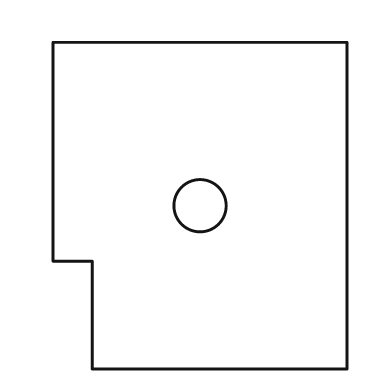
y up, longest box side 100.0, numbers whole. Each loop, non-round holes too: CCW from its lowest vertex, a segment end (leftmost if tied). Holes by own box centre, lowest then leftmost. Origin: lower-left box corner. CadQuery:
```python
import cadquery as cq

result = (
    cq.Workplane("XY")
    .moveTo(12.0, 0.0)
    .lineTo(90.0, 0.0)
    .lineTo(90.0, 100.0)
    .lineTo(0.0, 100.0)
    .lineTo(0.0, 33.0)
    .lineTo(12.0, 33.0)
    .close()
    .moveTo(45.0, 50.0)
    .circle(8.0)
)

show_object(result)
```